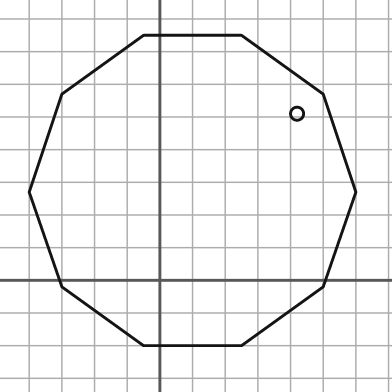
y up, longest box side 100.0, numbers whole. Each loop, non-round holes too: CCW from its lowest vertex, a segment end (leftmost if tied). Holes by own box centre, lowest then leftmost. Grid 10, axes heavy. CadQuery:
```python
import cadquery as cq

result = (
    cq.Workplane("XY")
    .moveTo(-5.0, -20.0)
    .lineTo(25.0, -20.0)
    .lineTo(50.0, -2.0)
    .lineTo(60.0, 27.0)
    .lineTo(50.0, 57.0)
    .lineTo(25.0, 75.0)
    .lineTo(-5.0, 75.0)
    .lineTo(-30.0, 57.0)
    .lineTo(-40.0, 27.0)
    .lineTo(-30.0, -2.0)
    .close()
    .moveTo(42.0, 51.0)
    .circle(2.0)
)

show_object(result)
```